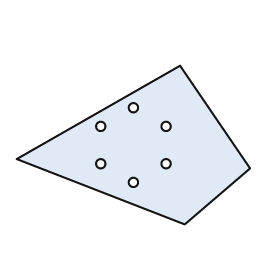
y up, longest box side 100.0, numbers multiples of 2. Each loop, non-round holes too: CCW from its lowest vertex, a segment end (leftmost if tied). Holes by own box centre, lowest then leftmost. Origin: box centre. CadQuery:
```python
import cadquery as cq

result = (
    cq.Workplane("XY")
    .moveTo(22.0, -34.0)
    .lineTo(50.0, -10.0)
    .lineTo(20.0, 34.0)
    .lineTo(-50.0, -6.0)
    .close()
    .moveTo(0.0, -16.0)
    .circle(2.0)
    .moveTo(-14.0, -8.0)
    .circle(2.0)
    .moveTo(14.0, -8.0)
    .circle(2.0)
    .moveTo(-14.0, 8.0)
    .circle(2.0)
    .moveTo(14.0, 8.0)
    .circle(2.0)
    .moveTo(0.0, 16.0)
    .circle(2.0)
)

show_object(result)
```